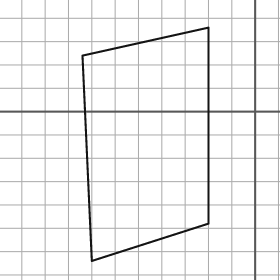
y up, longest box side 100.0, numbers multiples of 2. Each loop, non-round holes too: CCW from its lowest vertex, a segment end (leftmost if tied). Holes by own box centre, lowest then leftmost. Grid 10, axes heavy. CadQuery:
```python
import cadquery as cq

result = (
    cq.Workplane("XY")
    .moveTo(-70.0, -64.0)
    .lineTo(-20.0, -48.0)
    .lineTo(-20.0, 36.0)
    .lineTo(-74.0, 24.0)
    .close()
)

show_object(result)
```